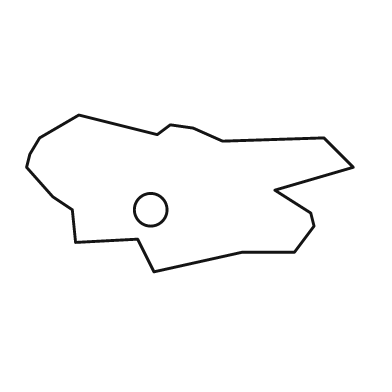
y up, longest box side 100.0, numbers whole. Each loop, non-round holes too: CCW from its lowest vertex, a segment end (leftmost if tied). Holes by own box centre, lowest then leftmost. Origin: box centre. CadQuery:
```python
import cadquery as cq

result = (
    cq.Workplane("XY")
    .moveTo(-11.0, -24.0)
    .lineTo(16.0, -18.0)
    .lineTo(32.0, -18.0)
    .lineTo(38.0, -10.0)
    .lineTo(37.0, -6.0)
    .lineTo(26.0, 1.0)
    .lineTo(50.0, 8.0)
    .lineTo(41.0, 17.0)
    .lineTo(10.0, 16.0)
    .lineTo(1.0, 20.0)
    .lineTo(-6.0, 21.0)
    .lineTo(-10.0, 18.0)
    .lineTo(-34.0, 24.0)
    .lineTo(-46.0, 17.0)
    .lineTo(-49.0, 12.0)
    .lineTo(-50.0, 8.0)
    .lineTo(-42.0, -1.0)
    .lineTo(-36.0, -5.0)
    .lineTo(-35.0, -15.0)
    .lineTo(-16.0, -14.0)
    .close()
    .moveTo(-12.0, -5.0)
    .circle(5.0)
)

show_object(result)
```